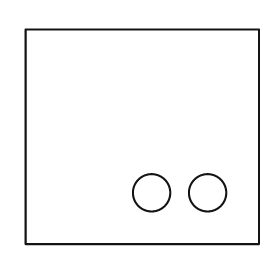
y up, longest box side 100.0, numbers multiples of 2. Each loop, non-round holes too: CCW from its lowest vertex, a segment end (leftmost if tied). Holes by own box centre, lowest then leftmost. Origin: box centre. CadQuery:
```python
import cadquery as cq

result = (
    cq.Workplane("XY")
    .moveTo(-50.0, -46.0)
    .lineTo(50.0, -46.0)
    .lineTo(50.0, 46.0)
    .lineTo(-50.0, 46.0)
    .close()
    .moveTo(4.0, -24.0)
    .circle(8.0)
    .moveTo(28.0, -24.0)
    .circle(8.0)
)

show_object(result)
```